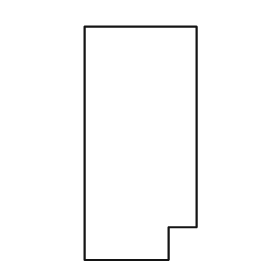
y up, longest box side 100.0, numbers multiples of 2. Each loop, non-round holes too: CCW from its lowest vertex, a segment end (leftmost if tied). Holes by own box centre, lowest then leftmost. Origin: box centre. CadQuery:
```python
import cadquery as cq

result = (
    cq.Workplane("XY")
    .moveTo(-24.0, -50.0)
    .lineTo(12.0, -50.0)
    .lineTo(12.0, -36.0)
    .lineTo(24.0, -36.0)
    .lineTo(24.0, 50.0)
    .lineTo(-24.0, 50.0)
    .close()
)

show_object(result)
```